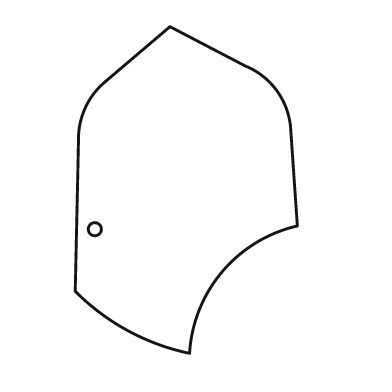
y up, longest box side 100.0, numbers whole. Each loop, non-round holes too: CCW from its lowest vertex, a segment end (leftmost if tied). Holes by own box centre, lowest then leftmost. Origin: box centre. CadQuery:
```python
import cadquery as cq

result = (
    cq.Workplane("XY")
    .moveTo(1.0, -50.0)
    .threePointArc((11.0, -25.0), (34.0, -11.0))
    .lineTo(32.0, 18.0)
    .threePointArc((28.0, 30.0), (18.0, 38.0))
    .lineTo(-5.0, 50.0)
    .lineTo(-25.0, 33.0)
    .threePointArc((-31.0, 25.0), (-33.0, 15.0))
    .lineTo(-34.0, -31.0)
    .threePointArc((-18.0, -43.0), (1.0, -50.0))
    .close()
    .moveTo(-28.0, -12.0)
    .circle(2.0)
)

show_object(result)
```